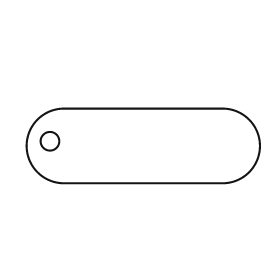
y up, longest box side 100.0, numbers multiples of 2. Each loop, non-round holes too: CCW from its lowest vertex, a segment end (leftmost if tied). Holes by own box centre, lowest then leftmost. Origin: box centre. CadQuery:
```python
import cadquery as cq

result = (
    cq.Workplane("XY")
    .moveTo(-34.0, -16.0)
    .lineTo(34.0, -16.0)
    .threePointArc((50.0, 0.0), (34.0, 16.0))
    .lineTo(-34.0, 16.0)
    .threePointArc((-50.0, 0.0), (-34.0, -16.0))
    .close()
    .moveTo(-40.0, 2.0)
    .circle(4.0)
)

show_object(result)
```